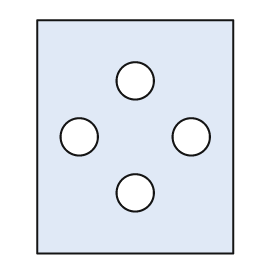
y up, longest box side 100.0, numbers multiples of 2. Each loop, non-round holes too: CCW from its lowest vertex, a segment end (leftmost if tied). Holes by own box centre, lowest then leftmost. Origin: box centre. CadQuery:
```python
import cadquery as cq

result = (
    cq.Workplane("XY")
    .moveTo(-42.0, -50.0)
    .lineTo(42.0, -50.0)
    .lineTo(42.0, 50.0)
    .lineTo(-42.0, 50.0)
    .close()
    .moveTo(0.0, -24.0)
    .circle(8.0)
    .moveTo(-24.0, 0.0)
    .circle(8.0)
    .moveTo(24.0, 0.0)
    .circle(8.0)
    .moveTo(0.0, 24.0)
    .circle(8.0)
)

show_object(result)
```